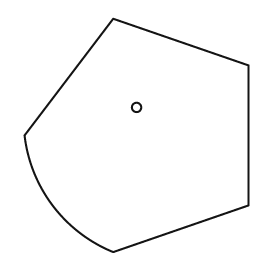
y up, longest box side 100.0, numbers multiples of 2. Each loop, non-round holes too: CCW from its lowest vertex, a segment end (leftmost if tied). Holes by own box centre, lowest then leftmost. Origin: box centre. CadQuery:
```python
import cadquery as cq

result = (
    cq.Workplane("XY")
    .moveTo(-10.0, -50.0)
    .lineTo(48.0, -30.0)
    .lineTo(48.0, 30.0)
    .lineTo(-10.0, 50.0)
    .lineTo(-48.0, 0.0)
    .threePointArc((-36.0, -30.0), (-10.0, -50.0))
    .close()
    .moveTo(0.0, 12.0)
    .circle(2.0)
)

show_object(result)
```